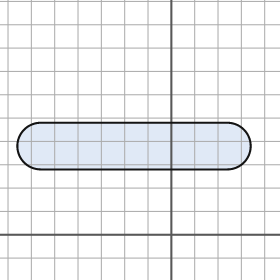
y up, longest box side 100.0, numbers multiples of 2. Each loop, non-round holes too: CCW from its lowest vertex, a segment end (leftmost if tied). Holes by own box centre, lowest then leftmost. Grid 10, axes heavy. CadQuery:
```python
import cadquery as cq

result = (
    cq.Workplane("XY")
    .moveTo(-56.0, 28.0)
    .lineTo(24.0, 28.0)
    .threePointArc((34.0, 38.0), (24.0, 48.0))
    .lineTo(-56.0, 48.0)
    .threePointArc((-66.0, 38.0), (-56.0, 28.0))
    .close()
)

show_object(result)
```